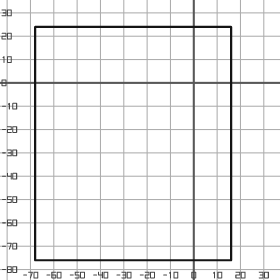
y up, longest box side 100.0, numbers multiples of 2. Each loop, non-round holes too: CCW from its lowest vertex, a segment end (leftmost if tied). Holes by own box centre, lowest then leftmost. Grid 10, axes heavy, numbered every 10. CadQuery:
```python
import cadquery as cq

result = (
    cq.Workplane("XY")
    .moveTo(-68.0, -76.0)
    .lineTo(16.0, -76.0)
    .lineTo(16.0, 24.0)
    .lineTo(-68.0, 24.0)
    .close()
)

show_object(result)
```